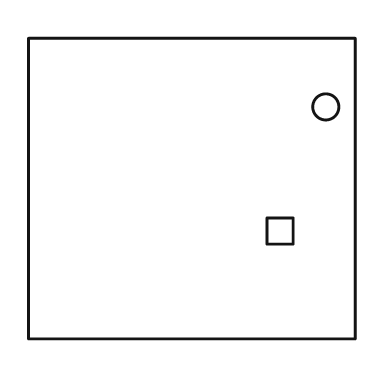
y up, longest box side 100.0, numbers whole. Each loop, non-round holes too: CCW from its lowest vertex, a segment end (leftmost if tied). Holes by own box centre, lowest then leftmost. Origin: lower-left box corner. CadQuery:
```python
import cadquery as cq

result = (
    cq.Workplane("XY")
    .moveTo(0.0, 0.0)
    .lineTo(100.0, 0.0)
    .lineTo(100.0, 92.0)
    .lineTo(0.0, 92.0)
    .close()
    .moveTo(73.0, 29.0)
    .lineTo(81.0, 29.0)
    .lineTo(81.0, 37.0)
    .lineTo(73.0, 37.0)
    .close()
    .moveTo(91.0, 71.0)
    .circle(4.0)
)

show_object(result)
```